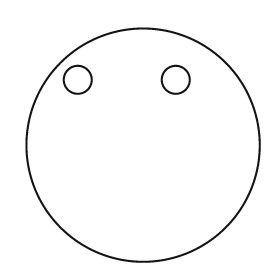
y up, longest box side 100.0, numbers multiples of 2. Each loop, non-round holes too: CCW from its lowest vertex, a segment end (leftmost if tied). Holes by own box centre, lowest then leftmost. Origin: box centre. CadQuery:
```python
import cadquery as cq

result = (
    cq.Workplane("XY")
    .moveTo(0.0, 0.0)
    .circle(50.0)
    .moveTo(-28.0, 28.0)
    .circle(6.0)
    .moveTo(14.0, 28.0)
    .circle(6.0)
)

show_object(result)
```